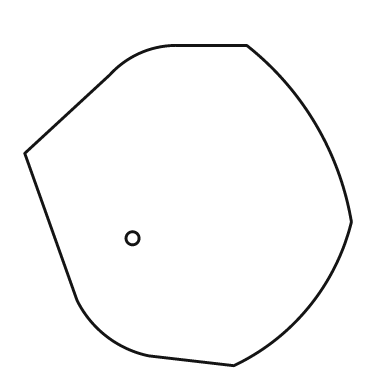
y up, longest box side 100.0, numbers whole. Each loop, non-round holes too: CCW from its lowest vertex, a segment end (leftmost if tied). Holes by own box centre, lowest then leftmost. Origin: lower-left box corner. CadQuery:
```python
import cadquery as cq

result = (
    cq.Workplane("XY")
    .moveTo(64.0, 0.0)
    .threePointArc((87.0, 18.0), (100.0, 44.0))
    .threePointArc((89.0, 74.0), (68.0, 98.0))
    .lineTo(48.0, 98.0)
    .threePointArc((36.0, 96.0), (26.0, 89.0))
    .lineTo(0.0, 65.0)
    .lineTo(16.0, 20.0)
    .threePointArc((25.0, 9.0), (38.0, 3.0))
    .close()
    .moveTo(33.0, 39.0)
    .circle(2.0)
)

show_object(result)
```